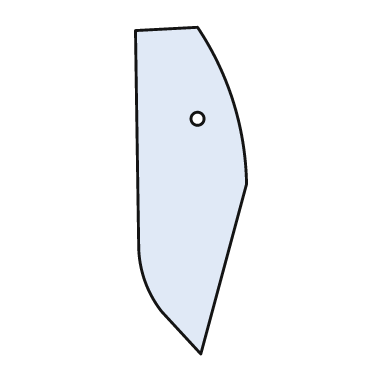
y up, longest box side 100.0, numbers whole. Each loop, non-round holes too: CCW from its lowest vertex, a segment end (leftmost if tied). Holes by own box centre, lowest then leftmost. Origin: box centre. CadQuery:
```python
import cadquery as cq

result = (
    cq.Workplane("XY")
    .moveTo(3.0, -50.0)
    .lineTo(17.0, 2.0)
    .threePointArc((13.0, 27.0), (2.0, 50.0))
    .lineTo(-17.0, 49.0)
    .lineTo(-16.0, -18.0)
    .threePointArc((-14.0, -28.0), (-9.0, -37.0))
    .close()
    .moveTo(2.0, 22.0)
    .circle(2.0)
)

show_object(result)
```